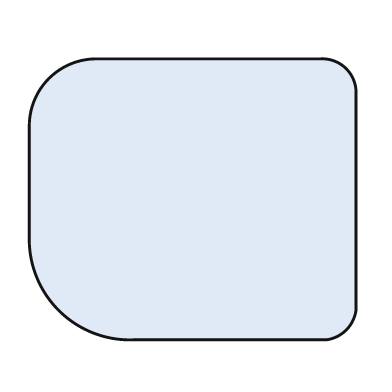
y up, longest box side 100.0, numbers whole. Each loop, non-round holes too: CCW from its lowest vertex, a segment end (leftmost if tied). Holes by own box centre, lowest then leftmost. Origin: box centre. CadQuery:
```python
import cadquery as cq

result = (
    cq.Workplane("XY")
    .moveTo(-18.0, -43.0)
    .lineTo(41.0, -43.0)
    .threePointArc((47.0, -40.0), (50.0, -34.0))
    .lineTo(50.0, 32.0)
    .threePointArc((47.0, 40.0), (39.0, 43.0))
    .lineTo(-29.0, 43.0)
    .threePointArc((-44.0, 37.0), (-50.0, 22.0))
    .lineTo(-50.0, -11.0)
    .threePointArc((-41.0, -34.0), (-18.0, -43.0))
    .close()
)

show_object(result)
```